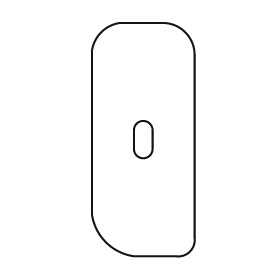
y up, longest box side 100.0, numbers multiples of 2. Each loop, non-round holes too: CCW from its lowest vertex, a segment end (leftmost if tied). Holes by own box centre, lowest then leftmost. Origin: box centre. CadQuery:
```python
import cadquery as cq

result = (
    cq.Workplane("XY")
    .moveTo(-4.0, -50.0)
    .lineTo(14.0, -50.0)
    .threePointArc((20.0, -48.0), (22.0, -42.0))
    .lineTo(22.0, 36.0)
    .threePointArc((18.0, 46.0), (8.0, 50.0))
    .lineTo(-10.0, 50.0)
    .threePointArc((-18.0, 46.0), (-22.0, 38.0))
    .lineTo(-22.0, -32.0)
    .threePointArc((-16.0, -44.0), (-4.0, -50.0))
    .close()
    .moveTo(-4.0, -4.0)
    .threePointArc((0.0, -8.0), (4.0, -4.0))
    .lineTo(4.0, 4.0)
    .threePointArc((0.0, 8.0), (-4.0, 4.0))
    .close()
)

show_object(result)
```